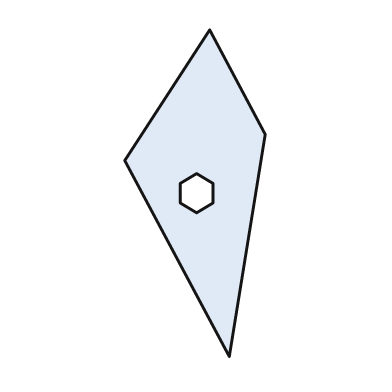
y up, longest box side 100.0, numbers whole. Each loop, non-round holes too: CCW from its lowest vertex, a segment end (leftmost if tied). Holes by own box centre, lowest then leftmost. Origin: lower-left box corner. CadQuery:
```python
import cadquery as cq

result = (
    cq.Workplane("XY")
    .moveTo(32.0, 0.0)
    .lineTo(43.0, 68.0)
    .lineTo(26.0, 100.0)
    .lineTo(0.0, 60.0)
    .close()
    .moveTo(22.0, 44.0)
    .lineTo(27.0, 47.0)
    .lineTo(27.0, 53.0)
    .lineTo(22.0, 56.0)
    .lineTo(17.0, 53.0)
    .lineTo(17.0, 47.0)
    .close()
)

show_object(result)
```